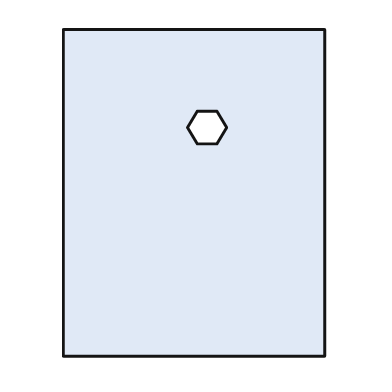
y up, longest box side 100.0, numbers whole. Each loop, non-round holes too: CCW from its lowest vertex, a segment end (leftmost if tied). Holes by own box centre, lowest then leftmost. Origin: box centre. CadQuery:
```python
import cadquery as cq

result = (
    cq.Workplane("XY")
    .moveTo(-40.0, -50.0)
    .lineTo(40.0, -50.0)
    .lineTo(40.0, 50.0)
    .lineTo(-40.0, 50.0)
    .close()
    .moveTo(1.0, 15.0)
    .lineTo(7.0, 15.0)
    .lineTo(10.0, 20.0)
    .lineTo(7.0, 25.0)
    .lineTo(1.0, 25.0)
    .lineTo(-2.0, 20.0)
    .close()
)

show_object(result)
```